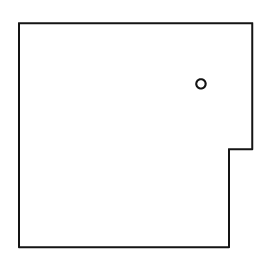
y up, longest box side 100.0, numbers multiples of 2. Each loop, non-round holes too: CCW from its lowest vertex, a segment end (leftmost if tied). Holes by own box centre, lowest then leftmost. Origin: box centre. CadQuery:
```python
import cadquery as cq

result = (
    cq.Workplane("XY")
    .moveTo(-50.0, -48.0)
    .lineTo(40.0, -48.0)
    .lineTo(40.0, -6.0)
    .lineTo(50.0, -6.0)
    .lineTo(50.0, 48.0)
    .lineTo(-50.0, 48.0)
    .close()
    .moveTo(28.0, 22.0)
    .circle(2.0)
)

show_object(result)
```